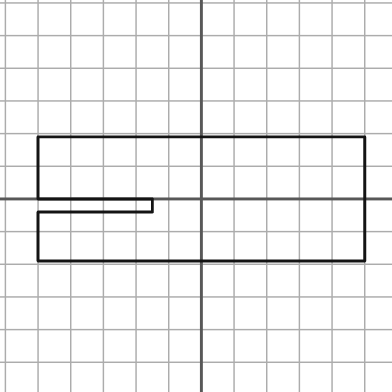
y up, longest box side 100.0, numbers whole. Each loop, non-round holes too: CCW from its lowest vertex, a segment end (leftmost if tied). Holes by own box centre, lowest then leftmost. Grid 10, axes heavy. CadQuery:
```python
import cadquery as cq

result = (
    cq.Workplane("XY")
    .moveTo(-50.0, -19.0)
    .lineTo(50.0, -19.0)
    .lineTo(50.0, 19.0)
    .lineTo(-50.0, 19.0)
    .lineTo(-50.0, 0.0)
    .lineTo(-15.0, 0.0)
    .lineTo(-15.0, -4.0)
    .lineTo(-50.0, -4.0)
    .close()
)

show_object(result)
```